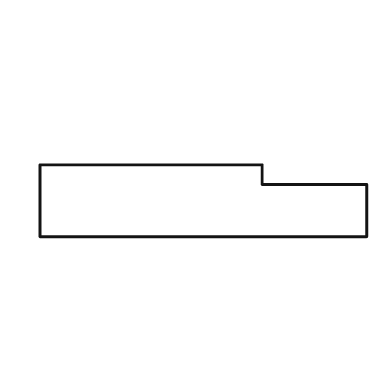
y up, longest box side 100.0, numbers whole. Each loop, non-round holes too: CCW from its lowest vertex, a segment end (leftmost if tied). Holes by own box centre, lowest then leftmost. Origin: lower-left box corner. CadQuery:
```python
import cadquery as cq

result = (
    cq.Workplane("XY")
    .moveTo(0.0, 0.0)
    .lineTo(100.0, 0.0)
    .lineTo(100.0, 16.0)
    .lineTo(68.0, 16.0)
    .lineTo(68.0, 22.0)
    .lineTo(0.0, 22.0)
    .close()
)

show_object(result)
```